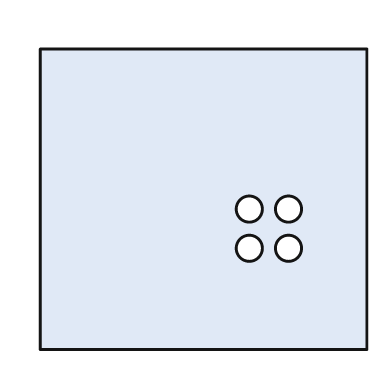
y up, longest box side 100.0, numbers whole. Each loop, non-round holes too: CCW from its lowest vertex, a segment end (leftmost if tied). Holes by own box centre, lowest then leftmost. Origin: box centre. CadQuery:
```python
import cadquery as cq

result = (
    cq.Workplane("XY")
    .moveTo(-50.0, -46.0)
    .lineTo(50.0, -46.0)
    .lineTo(50.0, 46.0)
    .lineTo(-50.0, 46.0)
    .close()
    .moveTo(14.0, -15.0)
    .circle(4.0)
    .moveTo(26.0, -15.0)
    .circle(4.0)
    .moveTo(14.0, -3.0)
    .circle(4.0)
    .moveTo(26.0, -3.0)
    .circle(4.0)
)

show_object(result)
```